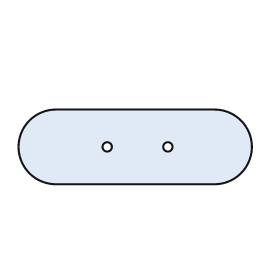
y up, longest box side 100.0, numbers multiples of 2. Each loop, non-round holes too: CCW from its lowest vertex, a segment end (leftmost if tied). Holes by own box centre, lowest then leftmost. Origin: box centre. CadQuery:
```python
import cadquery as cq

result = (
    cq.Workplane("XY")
    .moveTo(-34.0, -16.0)
    .lineTo(34.0, -16.0)
    .threePointArc((50.0, 0.0), (34.0, 16.0))
    .lineTo(-34.0, 16.0)
    .threePointArc((-50.0, 0.0), (-34.0, -16.0))
    .close()
    .moveTo(-12.0, 0.0)
    .circle(2.0)
    .moveTo(14.0, 0.0)
    .circle(2.0)
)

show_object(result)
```